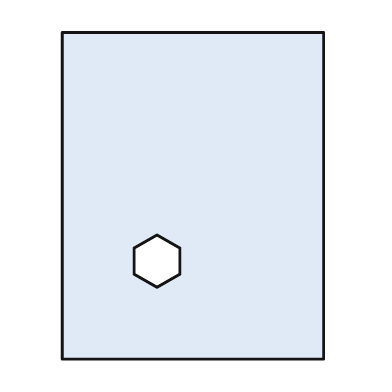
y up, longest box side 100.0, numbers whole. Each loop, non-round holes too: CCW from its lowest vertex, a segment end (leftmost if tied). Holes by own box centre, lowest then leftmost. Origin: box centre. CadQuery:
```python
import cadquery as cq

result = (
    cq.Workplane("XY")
    .moveTo(-40.0, -50.0)
    .lineTo(40.0, -50.0)
    .lineTo(40.0, 50.0)
    .lineTo(-40.0, 50.0)
    .close()
    .moveTo(-11.0, -28.0)
    .lineTo(-4.0, -24.0)
    .lineTo(-4.0, -16.0)
    .lineTo(-11.0, -12.0)
    .lineTo(-18.0, -16.0)
    .lineTo(-18.0, -24.0)
    .close()
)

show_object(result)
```